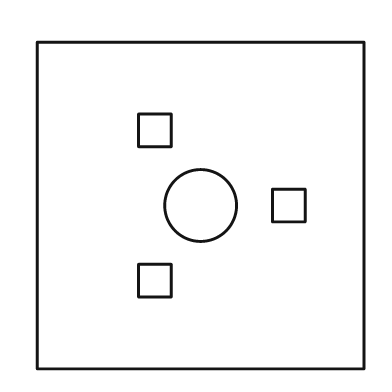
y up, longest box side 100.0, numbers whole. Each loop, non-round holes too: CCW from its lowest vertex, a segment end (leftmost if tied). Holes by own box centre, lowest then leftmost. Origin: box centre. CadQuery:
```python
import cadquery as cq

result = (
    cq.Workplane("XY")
    .moveTo(-50.0, -50.0)
    .lineTo(50.0, -50.0)
    .lineTo(50.0, 50.0)
    .lineTo(-50.0, 50.0)
    .close()
    .moveTo(-19.0, -28.0)
    .lineTo(-9.0, -28.0)
    .lineTo(-9.0, -18.0)
    .lineTo(-19.0, -18.0)
    .close()
    .moveTo(0.0, 0.0)
    .circle(11.0)
    .moveTo(22.0, -5.0)
    .lineTo(32.0, -5.0)
    .lineTo(32.0, 5.0)
    .lineTo(22.0, 5.0)
    .close()
    .moveTo(-19.0, 18.0)
    .lineTo(-9.0, 18.0)
    .lineTo(-9.0, 28.0)
    .lineTo(-19.0, 28.0)
    .close()
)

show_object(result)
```